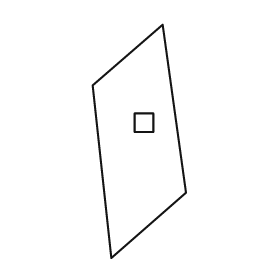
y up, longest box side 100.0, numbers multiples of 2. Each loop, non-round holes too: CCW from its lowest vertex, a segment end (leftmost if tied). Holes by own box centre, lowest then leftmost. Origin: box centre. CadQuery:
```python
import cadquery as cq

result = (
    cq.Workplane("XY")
    .moveTo(-12.0, -50.0)
    .lineTo(20.0, -22.0)
    .lineTo(10.0, 50.0)
    .lineTo(-20.0, 24.0)
    .close()
    .moveTo(-2.0, 4.0)
    .lineTo(6.0, 4.0)
    .lineTo(6.0, 12.0)
    .lineTo(-2.0, 12.0)
    .close()
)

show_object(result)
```